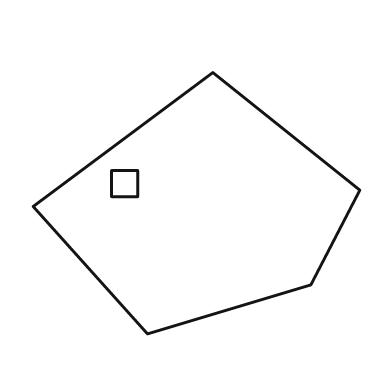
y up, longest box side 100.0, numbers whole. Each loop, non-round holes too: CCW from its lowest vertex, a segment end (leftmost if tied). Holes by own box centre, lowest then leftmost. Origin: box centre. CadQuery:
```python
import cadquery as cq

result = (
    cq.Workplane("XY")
    .moveTo(-15.0, -40.0)
    .lineTo(35.0, -25.0)
    .lineTo(50.0, 4.0)
    .lineTo(5.0, 40.0)
    .lineTo(-50.0, -1.0)
    .close()
    .moveTo(-26.0, 2.0)
    .lineTo(-18.0, 2.0)
    .lineTo(-18.0, 10.0)
    .lineTo(-26.0, 10.0)
    .close()
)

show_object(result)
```